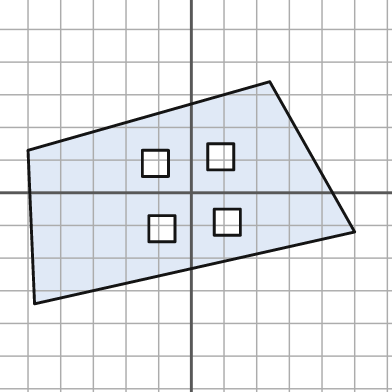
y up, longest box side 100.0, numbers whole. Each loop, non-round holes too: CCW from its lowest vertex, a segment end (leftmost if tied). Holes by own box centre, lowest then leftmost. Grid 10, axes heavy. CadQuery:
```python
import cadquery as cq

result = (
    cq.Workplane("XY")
    .moveTo(-48.0, -34.0)
    .lineTo(50.0, -12.0)
    .lineTo(24.0, 34.0)
    .lineTo(-50.0, 13.0)
    .close()
    .moveTo(-13.0, -15.0)
    .lineTo(-5.0, -15.0)
    .lineTo(-5.0, -7.0)
    .lineTo(-13.0, -7.0)
    .close()
    .moveTo(7.0, -13.0)
    .lineTo(15.0, -13.0)
    .lineTo(15.0, -5.0)
    .lineTo(7.0, -5.0)
    .close()
    .moveTo(-15.0, 5.0)
    .lineTo(-7.0, 5.0)
    .lineTo(-7.0, 13.0)
    .lineTo(-15.0, 13.0)
    .close()
    .moveTo(5.0, 7.0)
    .lineTo(13.0, 7.0)
    .lineTo(13.0, 15.0)
    .lineTo(5.0, 15.0)
    .close()
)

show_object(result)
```